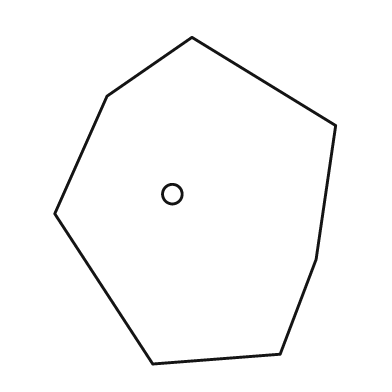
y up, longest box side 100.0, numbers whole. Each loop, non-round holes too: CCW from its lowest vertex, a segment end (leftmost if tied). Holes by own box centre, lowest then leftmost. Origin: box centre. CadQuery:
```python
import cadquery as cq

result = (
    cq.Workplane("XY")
    .moveTo(-13.0, -50.0)
    .lineTo(26.0, -47.0)
    .lineTo(37.0, -18.0)
    .lineTo(43.0, 23.0)
    .lineTo(-1.0, 50.0)
    .lineTo(-27.0, 32.0)
    .lineTo(-43.0, -4.0)
    .close()
    .moveTo(-7.0, 2.0)
    .circle(3.0)
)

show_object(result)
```